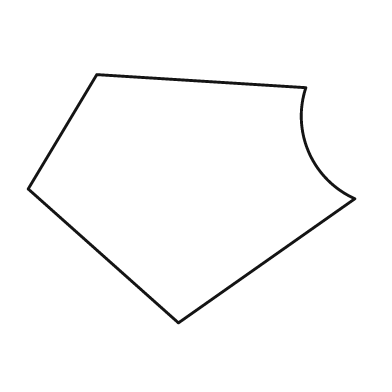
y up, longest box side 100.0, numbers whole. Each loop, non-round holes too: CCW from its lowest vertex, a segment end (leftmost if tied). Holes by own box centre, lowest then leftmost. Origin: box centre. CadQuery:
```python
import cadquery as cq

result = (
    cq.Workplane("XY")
    .moveTo(-4.0, -38.0)
    .lineTo(50.0, 0.0)
    .threePointArc((36.0, 14.0), (35.0, 34.0))
    .lineTo(-29.0, 38.0)
    .lineTo(-50.0, 3.0)
    .close()
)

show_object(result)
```